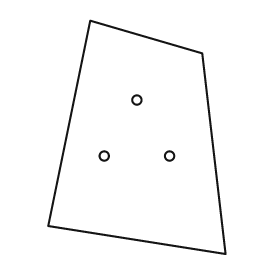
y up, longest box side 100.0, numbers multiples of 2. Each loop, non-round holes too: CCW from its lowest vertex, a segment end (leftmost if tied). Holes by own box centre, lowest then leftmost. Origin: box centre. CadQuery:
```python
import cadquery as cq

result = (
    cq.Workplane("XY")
    .moveTo(38.0, -50.0)
    .lineTo(28.0, 36.0)
    .lineTo(-20.0, 50.0)
    .lineTo(-38.0, -38.0)
    .close()
    .moveTo(-14.0, -8.0)
    .circle(2.0)
    .moveTo(14.0, -8.0)
    .circle(2.0)
    .moveTo(0.0, 16.0)
    .circle(2.0)
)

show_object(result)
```